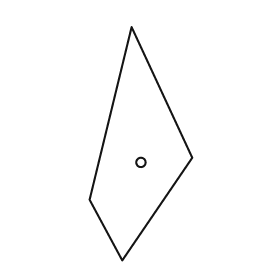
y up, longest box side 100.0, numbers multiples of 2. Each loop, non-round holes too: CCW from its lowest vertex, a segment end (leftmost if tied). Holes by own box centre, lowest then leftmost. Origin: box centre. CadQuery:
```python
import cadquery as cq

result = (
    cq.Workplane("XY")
    .moveTo(-8.0, -50.0)
    .lineTo(22.0, -6.0)
    .lineTo(-4.0, 50.0)
    .lineTo(-22.0, -24.0)
    .close()
    .moveTo(0.0, -8.0)
    .circle(2.0)
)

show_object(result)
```